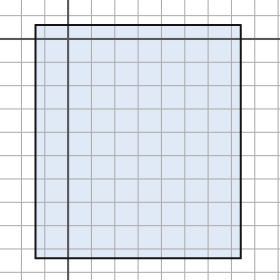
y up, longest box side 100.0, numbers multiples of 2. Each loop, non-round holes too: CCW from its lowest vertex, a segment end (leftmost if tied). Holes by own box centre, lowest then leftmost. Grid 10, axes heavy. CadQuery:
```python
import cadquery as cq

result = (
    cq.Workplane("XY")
    .moveTo(-14.0, -94.0)
    .lineTo(74.0, -94.0)
    .lineTo(74.0, 6.0)
    .lineTo(-14.0, 6.0)
    .close()
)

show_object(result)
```